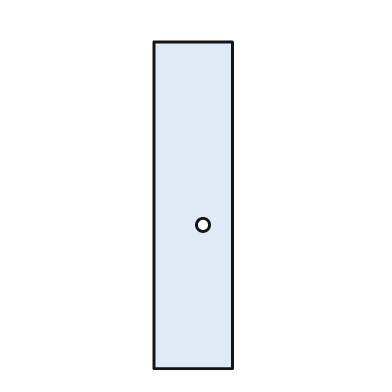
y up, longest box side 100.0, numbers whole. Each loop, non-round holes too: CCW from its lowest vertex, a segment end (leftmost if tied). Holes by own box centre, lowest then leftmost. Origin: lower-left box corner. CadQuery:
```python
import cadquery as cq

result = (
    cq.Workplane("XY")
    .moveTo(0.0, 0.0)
    .lineTo(24.0, 0.0)
    .lineTo(24.0, 100.0)
    .lineTo(0.0, 100.0)
    .close()
    .moveTo(15.0, 44.0)
    .circle(2.0)
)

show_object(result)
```